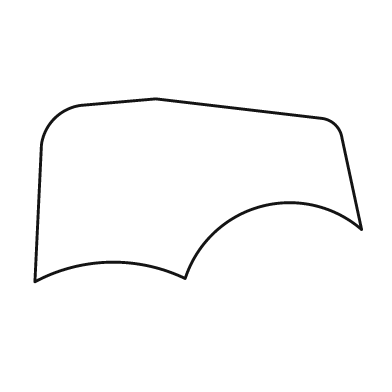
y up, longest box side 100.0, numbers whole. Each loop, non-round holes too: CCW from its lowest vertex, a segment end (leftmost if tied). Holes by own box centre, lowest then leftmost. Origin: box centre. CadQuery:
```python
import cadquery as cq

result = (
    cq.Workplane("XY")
    .moveTo(-50.0, -28.0)
    .threePointArc((-27.0, -22.0), (-4.0, -27.0))
    .threePointArc((19.0, -5.0), (50.0, -12.0))
    .lineTo(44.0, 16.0)
    .threePointArc((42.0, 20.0), (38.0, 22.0))
    .lineTo(-13.0, 28.0)
    .lineTo(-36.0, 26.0)
    .threePointArc((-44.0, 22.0), (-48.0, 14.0))
    .close()
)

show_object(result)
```